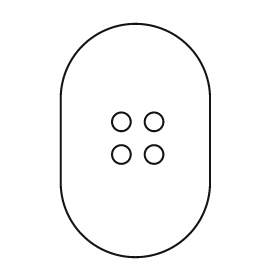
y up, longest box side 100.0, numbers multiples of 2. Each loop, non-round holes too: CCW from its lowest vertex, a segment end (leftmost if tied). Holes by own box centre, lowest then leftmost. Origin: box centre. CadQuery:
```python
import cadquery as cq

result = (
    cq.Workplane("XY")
    .moveTo(-32.0, -18.0)
    .threePointArc((0.0, -50.0), (32.0, -18.0))
    .lineTo(32.0, 18.0)
    .threePointArc((0.0, 50.0), (-32.0, 18.0))
    .close()
    .moveTo(-6.0, -6.0)
    .circle(4.0)
    .moveTo(8.0, -6.0)
    .circle(4.0)
    .moveTo(-6.0, 8.0)
    .circle(4.0)
    .moveTo(8.0, 8.0)
    .circle(4.0)
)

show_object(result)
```